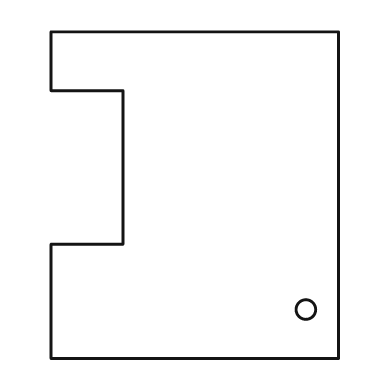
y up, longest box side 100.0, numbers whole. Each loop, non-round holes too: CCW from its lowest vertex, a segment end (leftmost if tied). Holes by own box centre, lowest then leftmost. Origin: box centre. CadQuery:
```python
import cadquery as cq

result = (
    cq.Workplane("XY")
    .moveTo(-44.0, -50.0)
    .lineTo(44.0, -50.0)
    .lineTo(44.0, 50.0)
    .lineTo(-44.0, 50.0)
    .lineTo(-44.0, 32.0)
    .lineTo(-22.0, 32.0)
    .lineTo(-22.0, -15.0)
    .lineTo(-44.0, -15.0)
    .close()
    .moveTo(34.0, -35.0)
    .circle(3.0)
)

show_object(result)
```